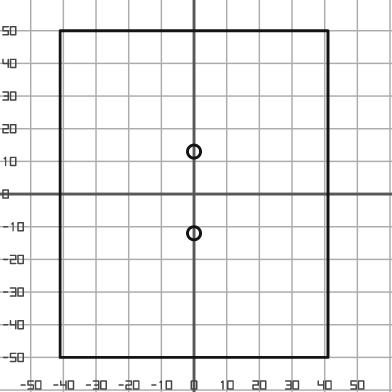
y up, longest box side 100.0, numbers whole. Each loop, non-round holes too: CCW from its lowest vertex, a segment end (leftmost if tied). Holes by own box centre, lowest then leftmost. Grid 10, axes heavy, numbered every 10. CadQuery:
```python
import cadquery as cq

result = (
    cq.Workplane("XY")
    .moveTo(-41.0, -50.0)
    .lineTo(41.0, -50.0)
    .lineTo(41.0, 50.0)
    .lineTo(-41.0, 50.0)
    .close()
    .moveTo(0.0, -12.0)
    .circle(2.0)
    .moveTo(0.0, 13.0)
    .circle(2.0)
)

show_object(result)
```